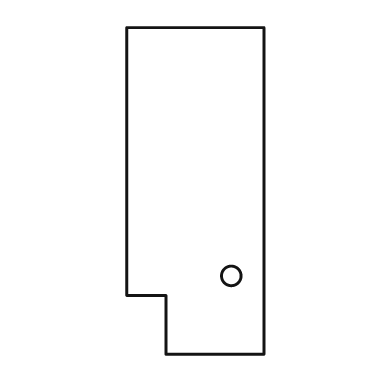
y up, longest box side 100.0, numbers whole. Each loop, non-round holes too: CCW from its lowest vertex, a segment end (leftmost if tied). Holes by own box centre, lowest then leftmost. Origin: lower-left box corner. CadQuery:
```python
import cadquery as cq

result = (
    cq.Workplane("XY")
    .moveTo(12.0, 0.0)
    .lineTo(42.0, 0.0)
    .lineTo(42.0, 100.0)
    .lineTo(0.0, 100.0)
    .lineTo(0.0, 18.0)
    .lineTo(12.0, 18.0)
    .close()
    .moveTo(32.0, 24.0)
    .circle(3.0)
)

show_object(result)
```